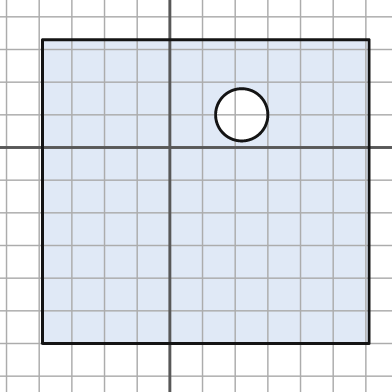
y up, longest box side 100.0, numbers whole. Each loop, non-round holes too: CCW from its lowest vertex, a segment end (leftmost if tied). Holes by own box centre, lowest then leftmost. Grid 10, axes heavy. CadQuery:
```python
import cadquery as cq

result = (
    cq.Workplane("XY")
    .moveTo(-39.0, -60.0)
    .lineTo(61.0, -60.0)
    .lineTo(61.0, 33.0)
    .lineTo(-39.0, 33.0)
    .close()
    .moveTo(22.0, 10.0)
    .circle(8.0)
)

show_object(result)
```